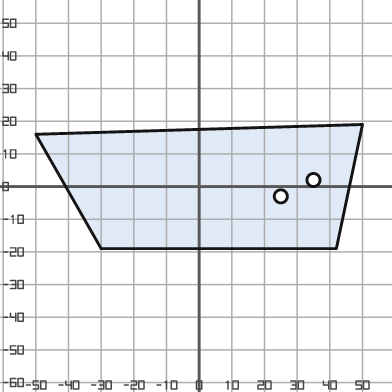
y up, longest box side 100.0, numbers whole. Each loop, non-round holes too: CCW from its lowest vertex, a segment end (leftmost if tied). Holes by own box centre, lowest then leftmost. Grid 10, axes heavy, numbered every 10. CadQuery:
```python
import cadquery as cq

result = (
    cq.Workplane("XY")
    .moveTo(-30.0, -19.0)
    .lineTo(42.0, -19.0)
    .lineTo(50.0, 19.0)
    .lineTo(-50.0, 16.0)
    .close()
    .moveTo(25.0, -3.0)
    .circle(2.0)
    .moveTo(35.0, 2.0)
    .circle(2.0)
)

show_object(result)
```